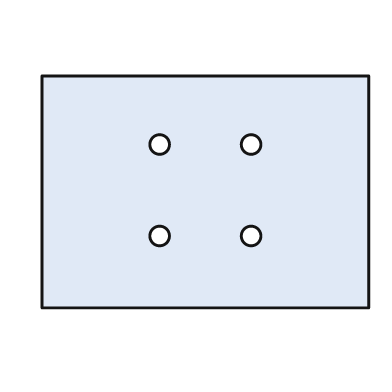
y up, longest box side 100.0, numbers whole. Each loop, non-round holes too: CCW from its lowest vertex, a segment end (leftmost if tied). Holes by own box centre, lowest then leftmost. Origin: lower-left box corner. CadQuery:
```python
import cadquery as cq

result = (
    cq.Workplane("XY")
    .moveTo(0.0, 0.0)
    .lineTo(100.0, 0.0)
    .lineTo(100.0, 71.0)
    .lineTo(0.0, 71.0)
    .close()
    .moveTo(36.0, 22.0)
    .circle(3.0)
    .moveTo(64.0, 22.0)
    .circle(3.0)
    .moveTo(36.0, 50.0)
    .circle(3.0)
    .moveTo(64.0, 50.0)
    .circle(3.0)
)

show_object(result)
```